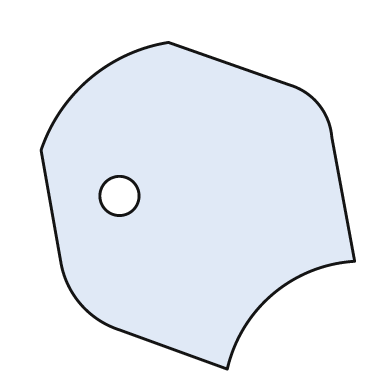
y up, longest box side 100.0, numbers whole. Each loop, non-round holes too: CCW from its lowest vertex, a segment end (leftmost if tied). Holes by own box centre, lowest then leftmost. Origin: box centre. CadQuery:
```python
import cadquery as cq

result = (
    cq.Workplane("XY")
    .moveTo(9.0, -50.0)
    .threePointArc((23.0, -27.0), (48.0, -17.0))
    .lineTo(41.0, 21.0)
    .threePointArc((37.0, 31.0), (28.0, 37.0))
    .lineTo(-9.0, 50.0)
    .threePointArc((-33.0, 39.0), (-48.0, 17.0))
    .lineTo(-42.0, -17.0)
    .threePointArc((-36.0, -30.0), (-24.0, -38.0))
    .close()
    .moveTo(-24.0, 3.0)
    .circle(6.0)
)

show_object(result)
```